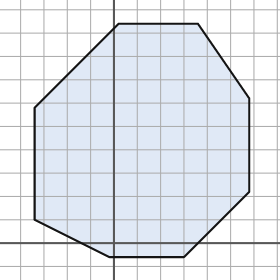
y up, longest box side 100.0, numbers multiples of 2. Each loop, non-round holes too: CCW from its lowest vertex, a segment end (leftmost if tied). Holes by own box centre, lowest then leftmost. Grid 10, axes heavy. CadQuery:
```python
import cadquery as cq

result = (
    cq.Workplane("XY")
    .moveTo(-2.0, -6.0)
    .lineTo(30.0, -6.0)
    .lineTo(58.0, 22.0)
    .lineTo(58.0, 62.0)
    .lineTo(36.0, 94.0)
    .lineTo(2.0, 94.0)
    .lineTo(-34.0, 58.0)
    .lineTo(-34.0, 10.0)
    .close()
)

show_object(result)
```